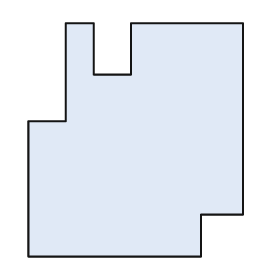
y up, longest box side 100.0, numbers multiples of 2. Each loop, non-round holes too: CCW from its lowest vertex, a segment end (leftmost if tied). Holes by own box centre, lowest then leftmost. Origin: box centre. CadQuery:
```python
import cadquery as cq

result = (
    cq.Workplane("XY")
    .moveTo(-46.0, -50.0)
    .lineTo(28.0, -50.0)
    .lineTo(28.0, -32.0)
    .lineTo(46.0, -32.0)
    .lineTo(46.0, 50.0)
    .lineTo(-2.0, 50.0)
    .lineTo(-2.0, 28.0)
    .lineTo(-18.0, 28.0)
    .lineTo(-18.0, 50.0)
    .lineTo(-30.0, 50.0)
    .lineTo(-30.0, 8.0)
    .lineTo(-46.0, 8.0)
    .close()
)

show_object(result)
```